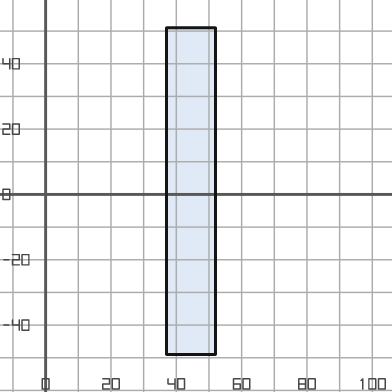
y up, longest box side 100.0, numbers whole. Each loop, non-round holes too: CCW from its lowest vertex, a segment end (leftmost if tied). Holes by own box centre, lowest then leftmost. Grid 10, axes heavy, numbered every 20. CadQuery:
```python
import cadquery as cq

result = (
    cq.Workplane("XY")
    .moveTo(37.0, -49.0)
    .lineTo(52.0, -49.0)
    .lineTo(52.0, 51.0)
    .lineTo(37.0, 51.0)
    .close()
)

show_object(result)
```